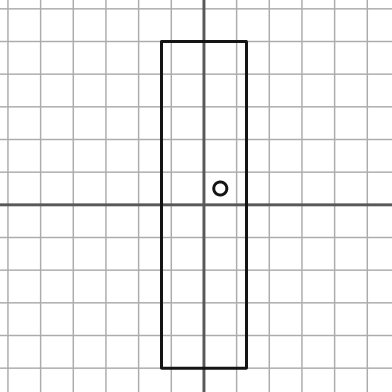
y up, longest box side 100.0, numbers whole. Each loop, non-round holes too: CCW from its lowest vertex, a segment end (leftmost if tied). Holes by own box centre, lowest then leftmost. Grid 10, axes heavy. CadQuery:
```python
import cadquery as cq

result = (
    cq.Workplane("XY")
    .moveTo(-13.0, -50.0)
    .lineTo(13.0, -50.0)
    .lineTo(13.0, 50.0)
    .lineTo(-13.0, 50.0)
    .close()
    .moveTo(5.0, 5.0)
    .circle(2.0)
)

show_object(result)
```